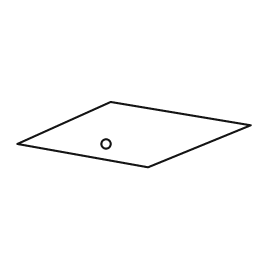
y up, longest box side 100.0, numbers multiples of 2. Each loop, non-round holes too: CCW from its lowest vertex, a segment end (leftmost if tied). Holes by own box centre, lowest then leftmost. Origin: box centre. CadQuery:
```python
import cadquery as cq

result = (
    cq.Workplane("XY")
    .moveTo(6.0, -14.0)
    .lineTo(50.0, 4.0)
    .lineTo(-10.0, 14.0)
    .lineTo(-50.0, -4.0)
    .close()
    .moveTo(-12.0, -4.0)
    .circle(2.0)
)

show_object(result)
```